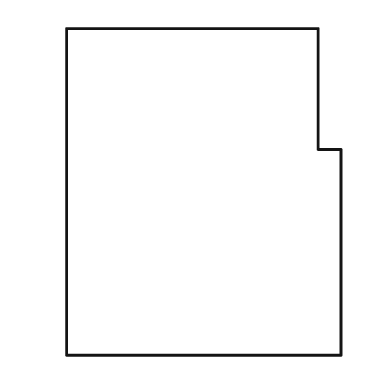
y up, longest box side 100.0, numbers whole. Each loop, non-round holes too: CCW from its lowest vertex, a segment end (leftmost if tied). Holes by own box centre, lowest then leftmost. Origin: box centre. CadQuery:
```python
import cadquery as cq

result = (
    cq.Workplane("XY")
    .moveTo(-42.0, -50.0)
    .lineTo(42.0, -50.0)
    .lineTo(42.0, 13.0)
    .lineTo(35.0, 13.0)
    .lineTo(35.0, 50.0)
    .lineTo(-42.0, 50.0)
    .close()
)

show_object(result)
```